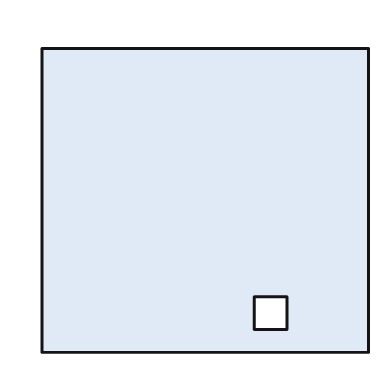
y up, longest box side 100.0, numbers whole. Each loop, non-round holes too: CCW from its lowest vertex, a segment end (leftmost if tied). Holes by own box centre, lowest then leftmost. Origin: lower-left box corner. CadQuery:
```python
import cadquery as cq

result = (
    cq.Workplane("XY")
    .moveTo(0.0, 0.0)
    .lineTo(100.0, 0.0)
    .lineTo(100.0, 93.0)
    .lineTo(0.0, 93.0)
    .close()
    .moveTo(65.0, 7.0)
    .lineTo(75.0, 7.0)
    .lineTo(75.0, 17.0)
    .lineTo(65.0, 17.0)
    .close()
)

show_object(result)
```